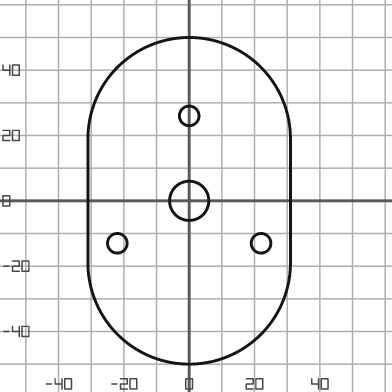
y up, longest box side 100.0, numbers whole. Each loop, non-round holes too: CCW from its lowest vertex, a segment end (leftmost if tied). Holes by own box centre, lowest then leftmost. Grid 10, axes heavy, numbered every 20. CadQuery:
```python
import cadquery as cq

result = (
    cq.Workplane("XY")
    .moveTo(-31.0, -19.0)
    .threePointArc((0.0, -50.0), (31.0, -19.0))
    .lineTo(31.0, 19.0)
    .threePointArc((0.0, 50.0), (-31.0, 19.0))
    .close()
    .moveTo(-22.0, -13.0)
    .circle(3.0)
    .moveTo(22.0, -13.0)
    .circle(3.0)
    .moveTo(0.0, 0.0)
    .circle(6.0)
    .moveTo(0.0, 26.0)
    .circle(3.0)
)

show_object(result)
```